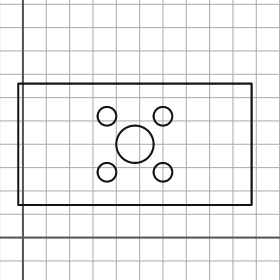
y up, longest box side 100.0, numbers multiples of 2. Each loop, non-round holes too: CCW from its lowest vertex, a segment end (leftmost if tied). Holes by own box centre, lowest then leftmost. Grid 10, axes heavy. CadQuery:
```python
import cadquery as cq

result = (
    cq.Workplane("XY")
    .moveTo(-2.0, 14.0)
    .lineTo(98.0, 14.0)
    .lineTo(98.0, 66.0)
    .lineTo(-2.0, 66.0)
    .close()
    .moveTo(36.0, 28.0)
    .circle(4.0)
    .moveTo(60.0, 28.0)
    .circle(4.0)
    .moveTo(48.0, 40.0)
    .circle(8.0)
    .moveTo(36.0, 52.0)
    .circle(4.0)
    .moveTo(60.0, 52.0)
    .circle(4.0)
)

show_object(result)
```